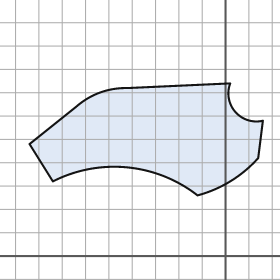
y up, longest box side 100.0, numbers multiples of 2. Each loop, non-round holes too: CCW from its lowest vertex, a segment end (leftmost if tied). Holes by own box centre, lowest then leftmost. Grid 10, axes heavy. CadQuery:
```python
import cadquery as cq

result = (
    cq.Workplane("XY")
    .moveTo(-12.0, 26.0)
    .threePointArc((2.0, 32.0), (14.0, 42.0))
    .lineTo(16.0, 58.0)
    .threePointArc((4.0, 62.0), (2.0, 74.0))
    .lineTo(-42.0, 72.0)
    .threePointArc((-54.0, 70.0), (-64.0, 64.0))
    .lineTo(-84.0, 48.0)
    .lineTo(-74.0, 32.0)
    .threePointArc((-42.0, 38.0), (-12.0, 26.0))
    .close()
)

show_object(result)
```